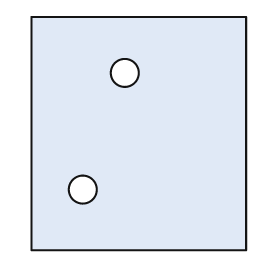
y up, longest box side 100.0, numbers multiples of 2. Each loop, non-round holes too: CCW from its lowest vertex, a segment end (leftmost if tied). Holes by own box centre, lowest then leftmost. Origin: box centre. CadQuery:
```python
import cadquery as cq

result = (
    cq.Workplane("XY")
    .moveTo(-46.0, -50.0)
    .lineTo(46.0, -50.0)
    .lineTo(46.0, 50.0)
    .lineTo(-46.0, 50.0)
    .close()
    .moveTo(-24.0, -24.0)
    .circle(6.0)
    .moveTo(-6.0, 26.0)
    .circle(6.0)
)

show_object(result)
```